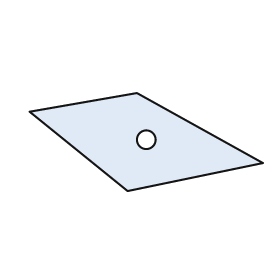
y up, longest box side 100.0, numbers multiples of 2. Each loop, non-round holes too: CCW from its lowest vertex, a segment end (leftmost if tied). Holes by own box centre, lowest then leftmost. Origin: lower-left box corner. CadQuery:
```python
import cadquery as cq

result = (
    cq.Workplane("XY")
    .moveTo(42.0, 0.0)
    .lineTo(100.0, 12.0)
    .lineTo(46.0, 42.0)
    .lineTo(0.0, 34.0)
    .close()
    .moveTo(50.0, 22.0)
    .circle(4.0)
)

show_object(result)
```